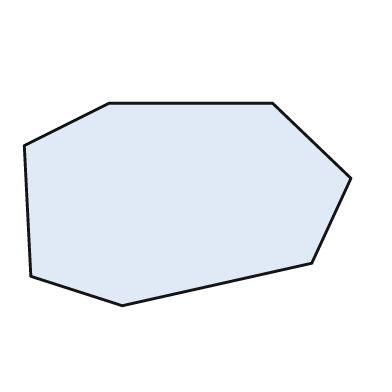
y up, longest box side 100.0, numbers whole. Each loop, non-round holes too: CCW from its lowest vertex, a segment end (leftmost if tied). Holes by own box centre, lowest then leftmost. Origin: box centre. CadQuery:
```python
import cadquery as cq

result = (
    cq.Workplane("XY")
    .moveTo(-20.0, -31.0)
    .lineTo(38.0, -18.0)
    .lineTo(50.0, 8.0)
    .lineTo(26.0, 31.0)
    .lineTo(-24.0, 31.0)
    .lineTo(-50.0, 18.0)
    .lineTo(-48.0, -22.0)
    .close()
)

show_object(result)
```